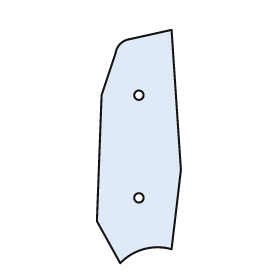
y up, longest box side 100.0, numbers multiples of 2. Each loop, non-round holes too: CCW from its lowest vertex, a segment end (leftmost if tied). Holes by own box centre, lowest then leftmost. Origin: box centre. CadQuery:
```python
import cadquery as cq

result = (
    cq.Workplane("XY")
    .moveTo(-8.0, -50.0)
    .threePointArc((2.0, -44.0), (14.0, -44.0))
    .lineTo(18.0, -10.0)
    .lineTo(14.0, 50.0)
    .lineTo(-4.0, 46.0)
    .threePointArc((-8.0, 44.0), (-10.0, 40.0))
    .lineTo(-16.0, 22.0)
    .lineTo(-18.0, -32.0)
    .close()
    .moveTo(0.0, -22.0)
    .circle(2.0)
    .moveTo(0.0, 22.0)
    .circle(2.0)
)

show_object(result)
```